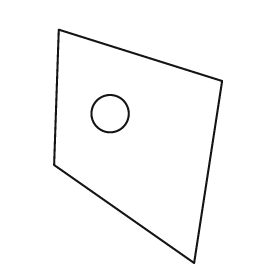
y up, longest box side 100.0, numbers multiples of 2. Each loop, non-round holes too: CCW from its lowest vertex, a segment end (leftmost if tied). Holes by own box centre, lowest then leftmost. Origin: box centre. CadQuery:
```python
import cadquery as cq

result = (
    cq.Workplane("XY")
    .moveTo(24.0, -50.0)
    .lineTo(36.0, 28.0)
    .lineTo(-34.0, 50.0)
    .lineTo(-36.0, -8.0)
    .close()
    .moveTo(-12.0, 14.0)
    .circle(8.0)
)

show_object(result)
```